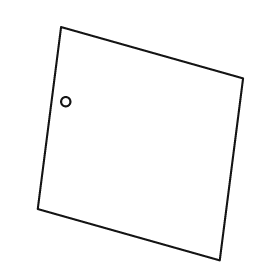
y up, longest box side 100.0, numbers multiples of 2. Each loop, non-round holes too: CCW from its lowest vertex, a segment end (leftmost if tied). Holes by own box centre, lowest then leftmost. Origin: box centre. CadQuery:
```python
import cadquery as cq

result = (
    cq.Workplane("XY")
    .moveTo(34.0, -50.0)
    .lineTo(44.0, 28.0)
    .lineTo(-34.0, 50.0)
    .lineTo(-44.0, -28.0)
    .close()
    .moveTo(-32.0, 18.0)
    .circle(2.0)
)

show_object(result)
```